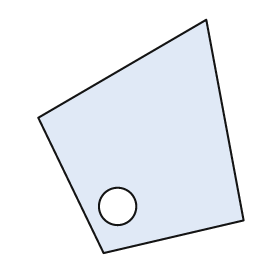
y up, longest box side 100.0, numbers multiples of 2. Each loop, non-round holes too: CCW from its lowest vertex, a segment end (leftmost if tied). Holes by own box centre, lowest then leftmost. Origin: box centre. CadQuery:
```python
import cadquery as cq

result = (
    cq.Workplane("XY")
    .moveTo(-16.0, -50.0)
    .lineTo(44.0, -36.0)
    .lineTo(28.0, 50.0)
    .lineTo(-44.0, 8.0)
    .close()
    .moveTo(-10.0, -30.0)
    .circle(8.0)
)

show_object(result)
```